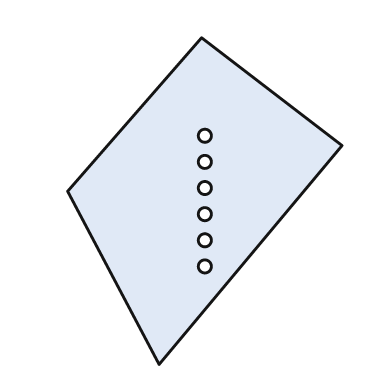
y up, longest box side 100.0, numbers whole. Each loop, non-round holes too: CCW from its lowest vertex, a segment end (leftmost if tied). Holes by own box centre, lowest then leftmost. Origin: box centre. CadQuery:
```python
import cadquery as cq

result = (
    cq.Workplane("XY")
    .moveTo(-14.0, -50.0)
    .lineTo(42.0, 17.0)
    .lineTo(-1.0, 50.0)
    .lineTo(-42.0, 3.0)
    .close()
    .moveTo(0.0, -20.0)
    .circle(2.0)
    .moveTo(0.0, -12.0)
    .circle(2.0)
    .moveTo(0.0, -4.0)
    .circle(2.0)
    .moveTo(0.0, 4.0)
    .circle(2.0)
    .moveTo(0.0, 12.0)
    .circle(2.0)
    .moveTo(0.0, 20.0)
    .circle(2.0)
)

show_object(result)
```